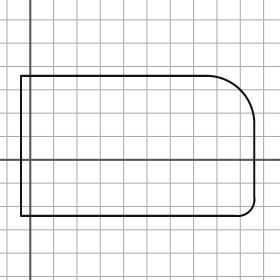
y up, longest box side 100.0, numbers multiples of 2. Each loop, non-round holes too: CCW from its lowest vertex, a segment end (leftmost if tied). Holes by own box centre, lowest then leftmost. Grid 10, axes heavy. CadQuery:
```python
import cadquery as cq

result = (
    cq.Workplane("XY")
    .moveTo(-4.0, -24.0)
    .lineTo(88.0, -24.0)
    .threePointArc((94.0, -22.0), (96.0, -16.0))
    .lineTo(96.0, 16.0)
    .threePointArc((90.0, 30.0), (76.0, 36.0))
    .lineTo(-4.0, 36.0)
    .close()
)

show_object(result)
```